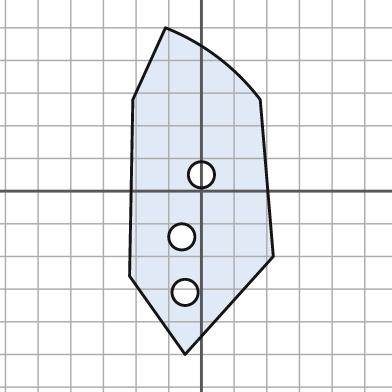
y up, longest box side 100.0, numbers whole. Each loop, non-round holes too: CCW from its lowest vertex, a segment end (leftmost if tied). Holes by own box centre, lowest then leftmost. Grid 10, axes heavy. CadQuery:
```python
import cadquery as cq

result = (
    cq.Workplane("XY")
    .moveTo(-5.0, -50.0)
    .lineTo(22.0, -20.0)
    .lineTo(18.0, 28.0)
    .threePointArc((5.0, 41.0), (-11.0, 50.0))
    .lineTo(-21.0, 28.0)
    .lineTo(-22.0, -26.0)
    .close()
    .moveTo(-5.0, -31.0)
    .circle(4.0)
    .moveTo(-6.0, -14.0)
    .circle(4.0)
    .moveTo(0.0, 5.0)
    .circle(4.0)
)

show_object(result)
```